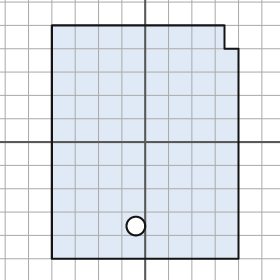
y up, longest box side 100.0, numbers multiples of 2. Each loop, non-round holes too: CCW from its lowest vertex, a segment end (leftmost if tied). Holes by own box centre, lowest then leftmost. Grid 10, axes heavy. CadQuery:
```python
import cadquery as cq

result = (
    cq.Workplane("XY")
    .moveTo(-40.0, -50.0)
    .lineTo(40.0, -50.0)
    .lineTo(40.0, 40.0)
    .lineTo(34.0, 40.0)
    .lineTo(34.0, 50.0)
    .lineTo(-40.0, 50.0)
    .close()
    .moveTo(-4.0, -36.0)
    .circle(4.0)
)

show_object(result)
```